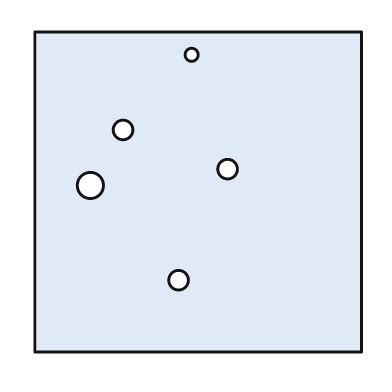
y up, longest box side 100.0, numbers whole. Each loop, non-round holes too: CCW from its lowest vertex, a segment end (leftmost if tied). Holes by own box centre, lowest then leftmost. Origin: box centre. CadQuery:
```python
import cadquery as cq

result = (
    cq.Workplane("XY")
    .moveTo(-50.0, -49.0)
    .lineTo(50.0, -49.0)
    .lineTo(50.0, 49.0)
    .lineTo(-50.0, 49.0)
    .close()
    .moveTo(-6.0, -27.0)
    .circle(3.0)
    .moveTo(-33.0, 2.0)
    .circle(4.0)
    .moveTo(9.0, 7.0)
    .circle(3.0)
    .moveTo(-23.0, 19.0)
    .circle(3.0)
    .moveTo(-2.0, 42.0)
    .circle(2.0)
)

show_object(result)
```